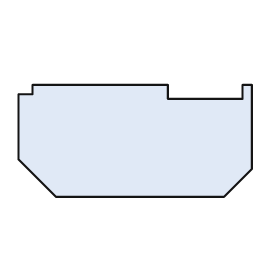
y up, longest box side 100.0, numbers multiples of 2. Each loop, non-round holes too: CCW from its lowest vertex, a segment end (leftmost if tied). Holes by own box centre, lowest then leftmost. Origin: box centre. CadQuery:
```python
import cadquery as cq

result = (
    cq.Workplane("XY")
    .moveTo(-34.0, -24.0)
    .lineTo(38.0, -24.0)
    .lineTo(50.0, -12.0)
    .lineTo(50.0, 24.0)
    .lineTo(46.0, 24.0)
    .lineTo(46.0, 18.0)
    .lineTo(14.0, 18.0)
    .lineTo(14.0, 24.0)
    .lineTo(-44.0, 24.0)
    .lineTo(-44.0, 20.0)
    .lineTo(-50.0, 20.0)
    .lineTo(-50.0, -8.0)
    .close()
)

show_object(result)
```